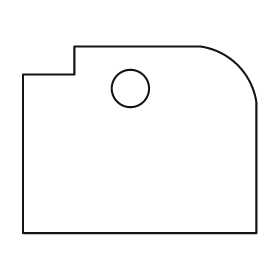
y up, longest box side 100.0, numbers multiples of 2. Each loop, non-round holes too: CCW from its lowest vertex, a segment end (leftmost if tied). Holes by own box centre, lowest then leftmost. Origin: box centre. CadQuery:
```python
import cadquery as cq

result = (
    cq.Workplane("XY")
    .moveTo(-50.0, -40.0)
    .lineTo(50.0, -40.0)
    .lineTo(50.0, 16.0)
    .threePointArc((42.0, 32.0), (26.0, 40.0))
    .lineTo(-28.0, 40.0)
    .lineTo(-28.0, 28.0)
    .lineTo(-50.0, 28.0)
    .close()
    .moveTo(-4.0, 22.0)
    .circle(8.0)
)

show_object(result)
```